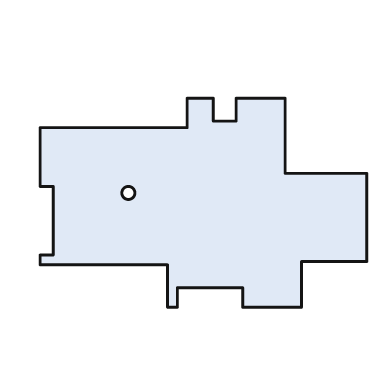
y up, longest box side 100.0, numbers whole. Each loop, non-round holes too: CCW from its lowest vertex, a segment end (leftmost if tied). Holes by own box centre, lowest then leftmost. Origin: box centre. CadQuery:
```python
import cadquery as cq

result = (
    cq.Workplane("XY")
    .moveTo(-11.0, -32.0)
    .lineTo(-8.0, -32.0)
    .lineTo(-8.0, -26.0)
    .lineTo(12.0, -26.0)
    .lineTo(12.0, -32.0)
    .lineTo(30.0, -32.0)
    .lineTo(30.0, -18.0)
    .lineTo(50.0, -18.0)
    .lineTo(50.0, 9.0)
    .lineTo(25.0, 9.0)
    .lineTo(25.0, 32.0)
    .lineTo(10.0, 32.0)
    .lineTo(10.0, 25.0)
    .lineTo(3.0, 25.0)
    .lineTo(3.0, 32.0)
    .lineTo(-5.0, 32.0)
    .lineTo(-5.0, 23.0)
    .lineTo(-50.0, 23.0)
    .lineTo(-50.0, 5.0)
    .lineTo(-46.0, 5.0)
    .lineTo(-46.0, -16.0)
    .lineTo(-50.0, -16.0)
    .lineTo(-50.0, -19.0)
    .lineTo(-11.0, -19.0)
    .close()
    .moveTo(-23.0, 3.0)
    .circle(2.0)
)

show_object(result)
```